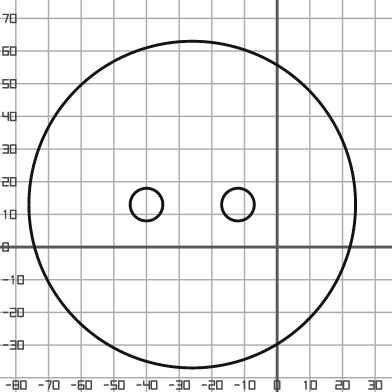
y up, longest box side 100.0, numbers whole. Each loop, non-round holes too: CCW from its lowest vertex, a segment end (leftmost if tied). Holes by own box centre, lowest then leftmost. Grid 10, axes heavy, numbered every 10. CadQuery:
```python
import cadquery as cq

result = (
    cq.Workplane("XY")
    .moveTo(-26.0, 13.0)
    .circle(50.0)
    .moveTo(-40.0, 13.0)
    .circle(5.0)
    .moveTo(-12.0, 13.0)
    .circle(5.0)
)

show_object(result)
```